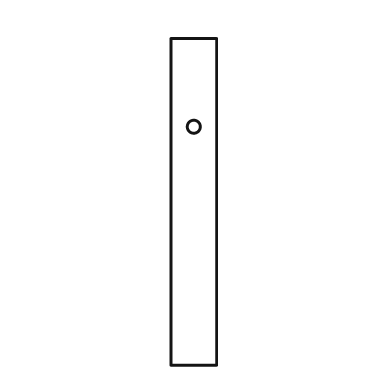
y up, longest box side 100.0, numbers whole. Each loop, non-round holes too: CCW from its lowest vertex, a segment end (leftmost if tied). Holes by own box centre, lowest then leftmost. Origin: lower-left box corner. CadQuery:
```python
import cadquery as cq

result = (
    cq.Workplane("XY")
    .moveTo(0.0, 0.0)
    .lineTo(14.0, 0.0)
    .lineTo(14.0, 100.0)
    .lineTo(0.0, 100.0)
    .close()
    .moveTo(7.0, 73.0)
    .circle(2.0)
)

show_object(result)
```